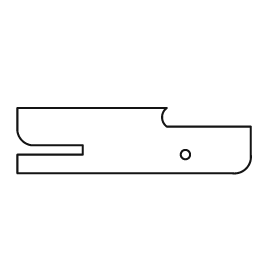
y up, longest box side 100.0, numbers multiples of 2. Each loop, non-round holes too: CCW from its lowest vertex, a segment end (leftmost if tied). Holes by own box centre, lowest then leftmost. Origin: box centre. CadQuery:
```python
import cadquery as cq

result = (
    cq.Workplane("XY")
    .moveTo(-50.0, -14.0)
    .lineTo(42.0, -14.0)
    .threePointArc((48.0, -12.0), (50.0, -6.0))
    .lineTo(50.0, 6.0)
    .lineTo(14.0, 6.0)
    .threePointArc((12.0, 10.0), (14.0, 14.0))
    .lineTo(-50.0, 14.0)
    .lineTo(-50.0, 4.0)
    .threePointArc((-48.0, 0.0), (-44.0, -2.0))
    .lineTo(-22.0, -2.0)
    .lineTo(-22.0, -6.0)
    .lineTo(-50.0, -6.0)
    .close()
    .moveTo(22.0, -6.0)
    .circle(2.0)
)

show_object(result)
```